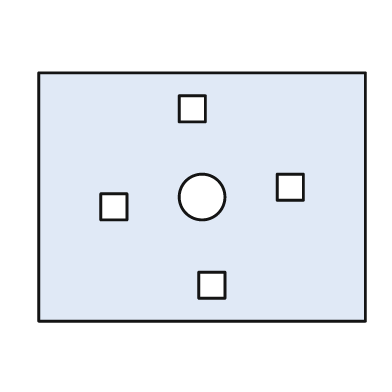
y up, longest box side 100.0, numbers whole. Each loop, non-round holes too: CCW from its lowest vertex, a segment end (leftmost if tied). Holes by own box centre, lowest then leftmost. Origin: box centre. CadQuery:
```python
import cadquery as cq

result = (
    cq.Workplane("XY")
    .moveTo(-50.0, -38.0)
    .lineTo(50.0, -38.0)
    .lineTo(50.0, 38.0)
    .lineTo(-50.0, 38.0)
    .close()
    .moveTo(-1.0, -31.0)
    .lineTo(7.0, -31.0)
    .lineTo(7.0, -23.0)
    .lineTo(-1.0, -23.0)
    .close()
    .moveTo(-31.0, -7.0)
    .lineTo(-23.0, -7.0)
    .lineTo(-23.0, 1.0)
    .lineTo(-31.0, 1.0)
    .close()
    .moveTo(0.0, 0.0)
    .circle(7.0)
    .moveTo(23.0, -1.0)
    .lineTo(31.0, -1.0)
    .lineTo(31.0, 7.0)
    .lineTo(23.0, 7.0)
    .close()
    .moveTo(-7.0, 23.0)
    .lineTo(1.0, 23.0)
    .lineTo(1.0, 31.0)
    .lineTo(-7.0, 31.0)
    .close()
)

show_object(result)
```